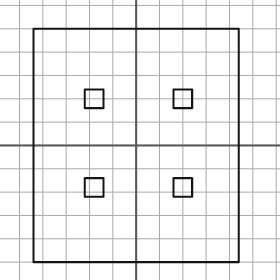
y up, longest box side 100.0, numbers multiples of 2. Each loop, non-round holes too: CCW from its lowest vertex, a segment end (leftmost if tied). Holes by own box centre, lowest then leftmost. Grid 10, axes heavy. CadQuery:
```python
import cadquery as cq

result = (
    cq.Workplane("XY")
    .moveTo(-44.0, -50.0)
    .lineTo(44.0, -50.0)
    .lineTo(44.0, 50.0)
    .lineTo(-44.0, 50.0)
    .close()
    .moveTo(-22.0, -22.0)
    .lineTo(-14.0, -22.0)
    .lineTo(-14.0, -14.0)
    .lineTo(-22.0, -14.0)
    .close()
    .moveTo(16.0, -22.0)
    .lineTo(24.0, -22.0)
    .lineTo(24.0, -14.0)
    .lineTo(16.0, -14.0)
    .close()
    .moveTo(-22.0, 16.0)
    .lineTo(-14.0, 16.0)
    .lineTo(-14.0, 24.0)
    .lineTo(-22.0, 24.0)
    .close()
    .moveTo(16.0, 16.0)
    .lineTo(24.0, 16.0)
    .lineTo(24.0, 24.0)
    .lineTo(16.0, 24.0)
    .close()
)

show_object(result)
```